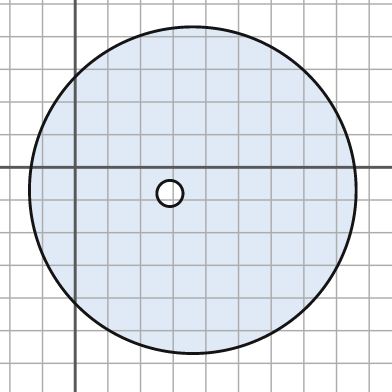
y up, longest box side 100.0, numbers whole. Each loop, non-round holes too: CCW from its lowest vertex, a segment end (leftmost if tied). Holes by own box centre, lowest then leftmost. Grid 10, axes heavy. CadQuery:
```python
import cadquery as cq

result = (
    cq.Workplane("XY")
    .moveTo(36.0, -7.0)
    .circle(50.0)
    .moveTo(29.0, -8.0)
    .circle(4.0)
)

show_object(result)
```